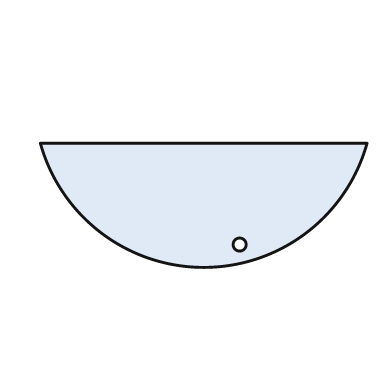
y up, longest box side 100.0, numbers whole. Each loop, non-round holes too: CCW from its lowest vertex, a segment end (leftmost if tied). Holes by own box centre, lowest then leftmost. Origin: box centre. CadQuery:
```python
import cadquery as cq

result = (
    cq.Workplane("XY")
    .moveTo(-50.0, 19.0)
    .threePointArc((0.0, -19.0), (50.0, 19.0))
    .close()
    .moveTo(11.0, -12.0)
    .circle(2.0)
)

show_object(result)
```